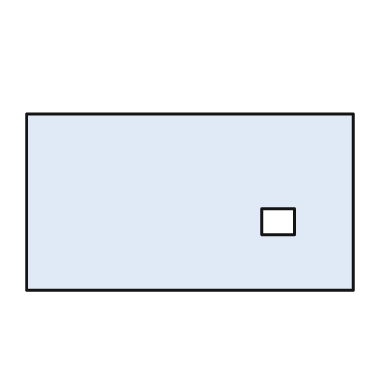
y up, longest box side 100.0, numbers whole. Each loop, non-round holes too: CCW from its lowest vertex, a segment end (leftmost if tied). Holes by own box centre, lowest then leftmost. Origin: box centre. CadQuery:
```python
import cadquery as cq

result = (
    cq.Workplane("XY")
    .moveTo(-50.0, -27.0)
    .lineTo(50.0, -27.0)
    .lineTo(50.0, 27.0)
    .lineTo(-50.0, 27.0)
    .close()
    .moveTo(22.0, -10.0)
    .lineTo(32.0, -10.0)
    .lineTo(32.0, -2.0)
    .lineTo(22.0, -2.0)
    .close()
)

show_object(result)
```